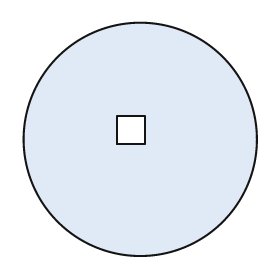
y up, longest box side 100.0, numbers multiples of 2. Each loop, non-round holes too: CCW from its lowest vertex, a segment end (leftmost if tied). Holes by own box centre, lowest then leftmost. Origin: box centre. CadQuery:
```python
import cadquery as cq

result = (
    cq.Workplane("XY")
    .moveTo(0.0, 0.0)
    .circle(50.0)
    .moveTo(-10.0, -2.0)
    .lineTo(2.0, -2.0)
    .lineTo(2.0, 10.0)
    .lineTo(-10.0, 10.0)
    .close()
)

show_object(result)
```